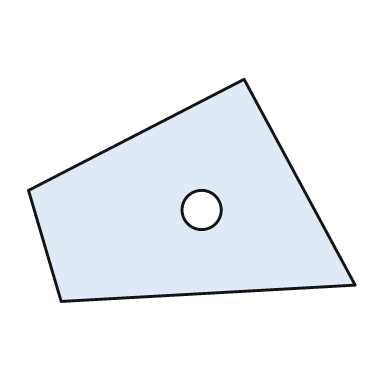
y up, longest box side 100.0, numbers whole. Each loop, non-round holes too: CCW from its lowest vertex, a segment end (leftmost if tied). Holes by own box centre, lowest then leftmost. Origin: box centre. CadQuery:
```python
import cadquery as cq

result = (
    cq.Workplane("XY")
    .moveTo(-40.0, -34.0)
    .lineTo(50.0, -29.0)
    .lineTo(16.0, 34.0)
    .lineTo(-50.0, 0.0)
    .close()
    .moveTo(3.0, -6.0)
    .circle(6.0)
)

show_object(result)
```